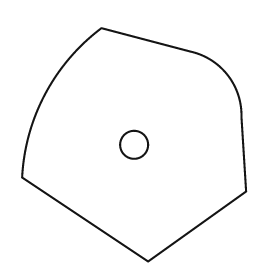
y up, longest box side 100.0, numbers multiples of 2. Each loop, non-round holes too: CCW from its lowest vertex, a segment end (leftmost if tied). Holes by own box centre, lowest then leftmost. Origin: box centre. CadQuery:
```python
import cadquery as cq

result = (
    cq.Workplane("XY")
    .moveTo(6.0, -50.0)
    .lineTo(48.0, -20.0)
    .lineTo(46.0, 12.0)
    .threePointArc((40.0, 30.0), (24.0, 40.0))
    .lineTo(-14.0, 50.0)
    .threePointArc((-38.0, 22.0), (-48.0, -14.0))
    .close()
    .moveTo(0.0, 0.0)
    .circle(6.0)
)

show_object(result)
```